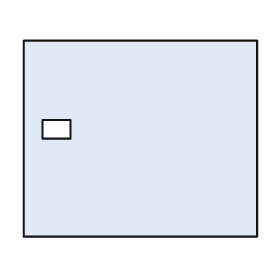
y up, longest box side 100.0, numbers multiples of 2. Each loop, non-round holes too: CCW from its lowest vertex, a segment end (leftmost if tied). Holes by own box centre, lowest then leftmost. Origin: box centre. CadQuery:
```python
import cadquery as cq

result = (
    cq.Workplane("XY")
    .moveTo(-50.0, -42.0)
    .lineTo(50.0, -42.0)
    .lineTo(50.0, 42.0)
    .lineTo(-50.0, 42.0)
    .close()
    .moveTo(-42.0, 0.0)
    .lineTo(-30.0, 0.0)
    .lineTo(-30.0, 8.0)
    .lineTo(-42.0, 8.0)
    .close()
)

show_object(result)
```